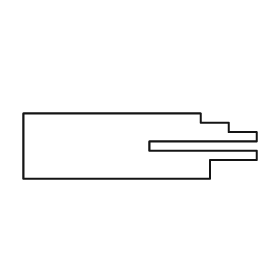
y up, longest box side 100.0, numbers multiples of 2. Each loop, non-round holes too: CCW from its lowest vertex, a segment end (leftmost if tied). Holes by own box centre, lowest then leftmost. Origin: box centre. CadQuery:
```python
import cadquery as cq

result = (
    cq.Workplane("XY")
    .moveTo(-50.0, -14.0)
    .lineTo(30.0, -14.0)
    .lineTo(30.0, -6.0)
    .lineTo(50.0, -6.0)
    .lineTo(50.0, -2.0)
    .lineTo(4.0, -2.0)
    .lineTo(4.0, 2.0)
    .lineTo(50.0, 2.0)
    .lineTo(50.0, 6.0)
    .lineTo(38.0, 6.0)
    .lineTo(38.0, 10.0)
    .lineTo(26.0, 10.0)
    .lineTo(26.0, 14.0)
    .lineTo(-50.0, 14.0)
    .close()
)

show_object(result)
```